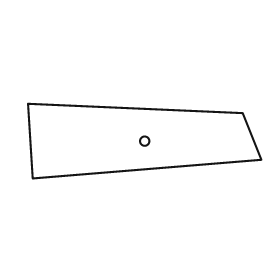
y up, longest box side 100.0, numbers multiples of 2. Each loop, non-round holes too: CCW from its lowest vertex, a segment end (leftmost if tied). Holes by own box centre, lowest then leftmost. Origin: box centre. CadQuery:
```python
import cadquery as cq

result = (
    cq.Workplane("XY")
    .moveTo(-48.0, -16.0)
    .lineTo(50.0, -8.0)
    .lineTo(42.0, 12.0)
    .lineTo(-50.0, 16.0)
    .close()
    .moveTo(0.0, 0.0)
    .circle(2.0)
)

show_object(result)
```